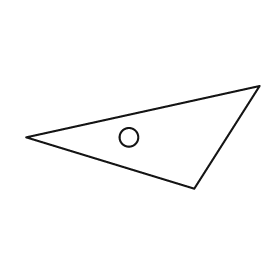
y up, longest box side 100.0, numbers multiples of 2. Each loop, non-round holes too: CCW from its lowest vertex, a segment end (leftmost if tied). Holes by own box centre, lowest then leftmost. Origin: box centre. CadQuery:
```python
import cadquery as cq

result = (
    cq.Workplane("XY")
    .moveTo(22.0, -22.0)
    .lineTo(50.0, 22.0)
    .lineTo(-50.0, 0.0)
    .close()
    .moveTo(-6.0, 0.0)
    .circle(4.0)
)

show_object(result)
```